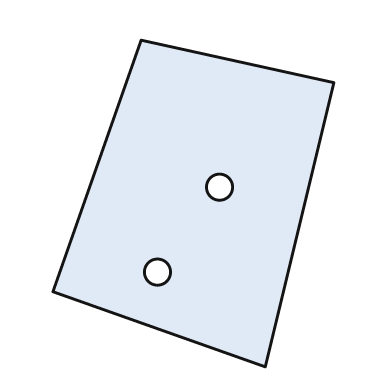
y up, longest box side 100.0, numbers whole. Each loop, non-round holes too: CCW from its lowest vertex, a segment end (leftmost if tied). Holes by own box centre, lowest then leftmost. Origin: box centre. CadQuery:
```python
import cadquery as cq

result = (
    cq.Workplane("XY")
    .moveTo(22.0, -50.0)
    .lineTo(43.0, 37.0)
    .lineTo(-16.0, 50.0)
    .lineTo(-43.0, -27.0)
    .close()
    .moveTo(-11.0, -21.0)
    .circle(4.0)
    .moveTo(8.0, 5.0)
    .circle(4.0)
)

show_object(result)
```